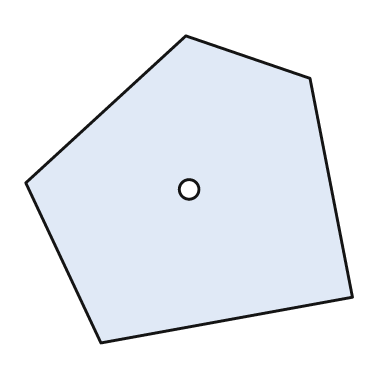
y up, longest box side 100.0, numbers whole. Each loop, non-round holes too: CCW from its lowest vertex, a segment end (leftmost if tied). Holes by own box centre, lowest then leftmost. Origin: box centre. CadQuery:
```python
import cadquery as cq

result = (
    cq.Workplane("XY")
    .moveTo(-27.0, -47.0)
    .lineTo(50.0, -33.0)
    .lineTo(37.0, 34.0)
    .lineTo(-1.0, 47.0)
    .lineTo(-50.0, 2.0)
    .close()
    .moveTo(0.0, 0.0)
    .circle(3.0)
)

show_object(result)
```